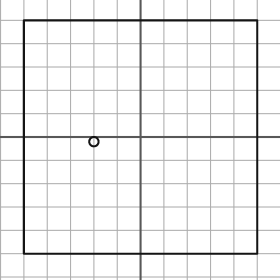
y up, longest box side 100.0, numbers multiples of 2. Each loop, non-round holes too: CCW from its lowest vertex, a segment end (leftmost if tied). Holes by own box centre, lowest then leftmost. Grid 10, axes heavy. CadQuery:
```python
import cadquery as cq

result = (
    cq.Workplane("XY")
    .moveTo(-50.0, -50.0)
    .lineTo(50.0, -50.0)
    .lineTo(50.0, 50.0)
    .lineTo(-50.0, 50.0)
    .close()
    .moveTo(-20.0, -2.0)
    .circle(2.0)
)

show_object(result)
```